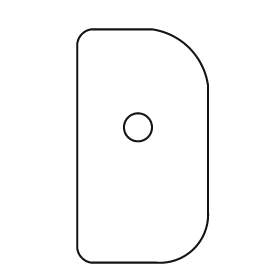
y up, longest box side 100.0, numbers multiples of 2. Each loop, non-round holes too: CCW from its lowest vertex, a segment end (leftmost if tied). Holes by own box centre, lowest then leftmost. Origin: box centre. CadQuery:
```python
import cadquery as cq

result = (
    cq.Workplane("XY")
    .moveTo(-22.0, -50.0)
    .lineTo(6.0, -50.0)
    .threePointArc((22.0, -44.0), (28.0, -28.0))
    .lineTo(28.0, 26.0)
    .threePointArc((20.0, 42.0), (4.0, 50.0))
    .lineTo(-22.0, 50.0)
    .threePointArc((-26.0, 48.0), (-28.0, 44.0))
    .lineTo(-28.0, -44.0)
    .threePointArc((-26.0, -48.0), (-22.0, -50.0))
    .close()
    .moveTo(-2.0, 8.0)
    .circle(6.0)
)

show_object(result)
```